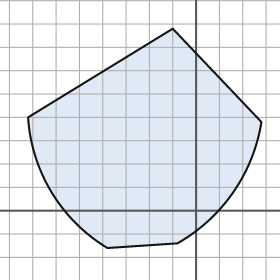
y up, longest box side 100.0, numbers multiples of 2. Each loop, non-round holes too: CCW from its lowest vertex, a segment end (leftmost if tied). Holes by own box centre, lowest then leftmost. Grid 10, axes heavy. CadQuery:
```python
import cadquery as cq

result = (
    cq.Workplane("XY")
    .moveTo(-38.0, -16.0)
    .lineTo(-8.0, -14.0)
    .threePointArc((16.0, 8.0), (28.0, 38.0))
    .lineTo(-10.0, 78.0)
    .lineTo(-72.0, 40.0)
    .threePointArc((-62.0, 8.0), (-38.0, -16.0))
    .close()
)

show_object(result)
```